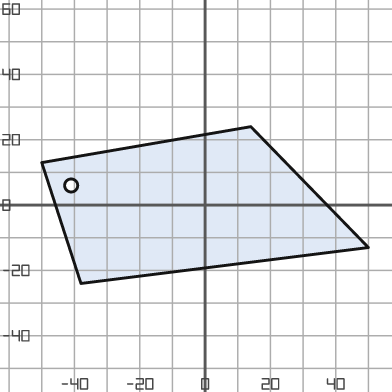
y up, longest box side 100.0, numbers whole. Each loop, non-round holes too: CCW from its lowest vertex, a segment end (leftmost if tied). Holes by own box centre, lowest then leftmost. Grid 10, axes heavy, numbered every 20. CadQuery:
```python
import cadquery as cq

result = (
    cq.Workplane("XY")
    .moveTo(-38.0, -24.0)
    .lineTo(50.0, -13.0)
    .lineTo(14.0, 24.0)
    .lineTo(-50.0, 13.0)
    .close()
    .moveTo(-41.0, 6.0)
    .circle(2.0)
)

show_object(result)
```